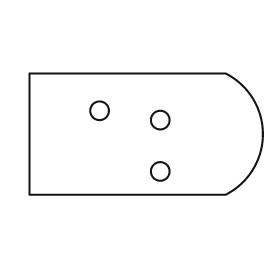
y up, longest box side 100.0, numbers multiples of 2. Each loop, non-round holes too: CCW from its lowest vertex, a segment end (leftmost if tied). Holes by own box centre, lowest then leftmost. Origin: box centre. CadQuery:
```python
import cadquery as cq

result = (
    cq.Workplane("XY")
    .moveTo(-50.0, -26.0)
    .lineTo(34.0, -26.0)
    .threePointArc((50.0, 0.0), (34.0, 26.0))
    .lineTo(-50.0, 26.0)
    .close()
    .moveTo(6.0, -16.0)
    .circle(4.0)
    .moveTo(6.0, 6.0)
    .circle(4.0)
    .moveTo(-20.0, 10.0)
    .circle(4.0)
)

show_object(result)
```